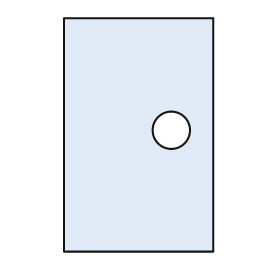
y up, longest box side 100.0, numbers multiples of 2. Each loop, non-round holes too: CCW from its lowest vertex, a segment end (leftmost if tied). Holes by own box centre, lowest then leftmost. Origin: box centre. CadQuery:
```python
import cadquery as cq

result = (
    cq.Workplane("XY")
    .moveTo(-32.0, -50.0)
    .lineTo(32.0, -50.0)
    .lineTo(32.0, 50.0)
    .lineTo(-32.0, 50.0)
    .close()
    .moveTo(14.0, 2.0)
    .circle(8.0)
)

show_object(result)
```